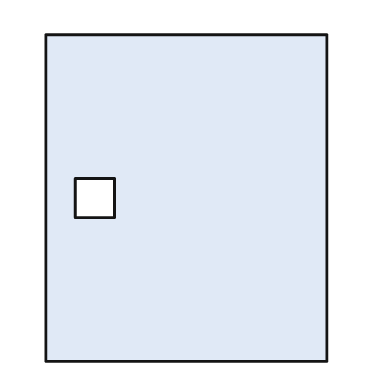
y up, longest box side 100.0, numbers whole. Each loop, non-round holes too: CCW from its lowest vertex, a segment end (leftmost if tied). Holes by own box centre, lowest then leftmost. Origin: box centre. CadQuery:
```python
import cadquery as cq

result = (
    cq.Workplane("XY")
    .moveTo(-43.0, -50.0)
    .lineTo(43.0, -50.0)
    .lineTo(43.0, 50.0)
    .lineTo(-43.0, 50.0)
    .close()
    .moveTo(-34.0, -6.0)
    .lineTo(-22.0, -6.0)
    .lineTo(-22.0, 6.0)
    .lineTo(-34.0, 6.0)
    .close()
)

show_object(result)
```